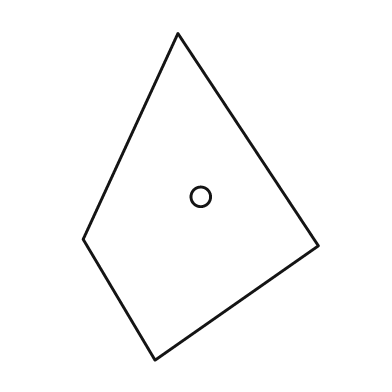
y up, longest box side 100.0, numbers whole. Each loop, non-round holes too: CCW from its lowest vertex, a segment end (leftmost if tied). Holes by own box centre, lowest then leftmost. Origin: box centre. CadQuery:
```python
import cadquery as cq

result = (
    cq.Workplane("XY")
    .moveTo(-14.0, -50.0)
    .lineTo(36.0, -15.0)
    .lineTo(-7.0, 50.0)
    .lineTo(-36.0, -13.0)
    .close()
    .moveTo(0.0, 0.0)
    .circle(3.0)
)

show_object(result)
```